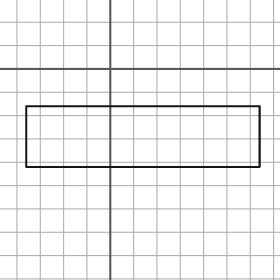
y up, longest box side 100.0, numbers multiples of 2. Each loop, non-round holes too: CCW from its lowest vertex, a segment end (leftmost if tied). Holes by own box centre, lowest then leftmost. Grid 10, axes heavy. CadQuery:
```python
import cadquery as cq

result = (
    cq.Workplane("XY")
    .moveTo(-36.0, -42.0)
    .lineTo(64.0, -42.0)
    .lineTo(64.0, -16.0)
    .lineTo(-36.0, -16.0)
    .close()
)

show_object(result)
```